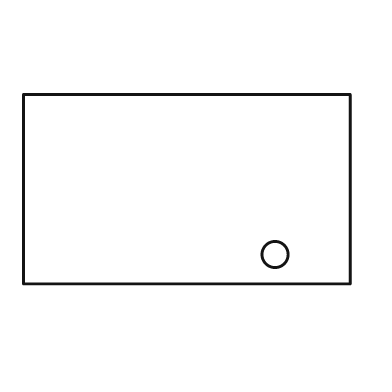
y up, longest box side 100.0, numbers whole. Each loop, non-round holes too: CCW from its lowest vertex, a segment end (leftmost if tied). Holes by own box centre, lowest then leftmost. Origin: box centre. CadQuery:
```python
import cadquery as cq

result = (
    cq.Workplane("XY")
    .moveTo(-50.0, -29.0)
    .lineTo(50.0, -29.0)
    .lineTo(50.0, 29.0)
    .lineTo(-50.0, 29.0)
    .close()
    .moveTo(27.0, -20.0)
    .circle(4.0)
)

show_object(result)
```